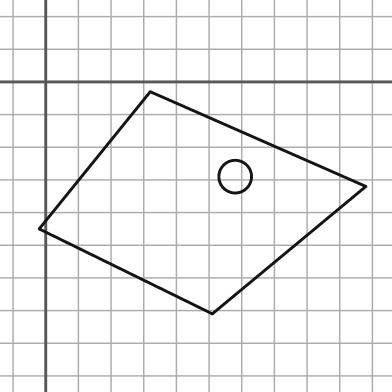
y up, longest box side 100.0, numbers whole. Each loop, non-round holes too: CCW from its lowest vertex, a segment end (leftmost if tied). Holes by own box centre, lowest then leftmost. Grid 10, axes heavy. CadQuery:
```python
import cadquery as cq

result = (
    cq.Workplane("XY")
    .moveTo(51.0, -71.0)
    .lineTo(98.0, -32.0)
    .lineTo(32.0, -3.0)
    .lineTo(-2.0, -45.0)
    .close()
    .moveTo(58.0, -29.0)
    .circle(5.0)
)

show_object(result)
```